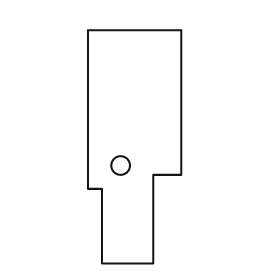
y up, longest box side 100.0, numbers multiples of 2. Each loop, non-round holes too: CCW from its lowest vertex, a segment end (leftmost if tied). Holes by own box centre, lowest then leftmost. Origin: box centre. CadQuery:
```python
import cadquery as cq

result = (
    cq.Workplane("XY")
    .moveTo(-14.0, -50.0)
    .lineTo(8.0, -50.0)
    .lineTo(8.0, -12.0)
    .lineTo(20.0, -12.0)
    .lineTo(20.0, 50.0)
    .lineTo(-20.0, 50.0)
    .lineTo(-20.0, -18.0)
    .lineTo(-14.0, -18.0)
    .close()
    .moveTo(-6.0, -8.0)
    .circle(4.0)
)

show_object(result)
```